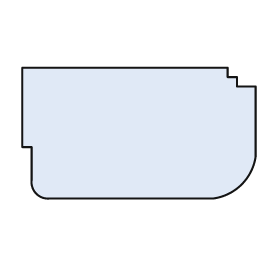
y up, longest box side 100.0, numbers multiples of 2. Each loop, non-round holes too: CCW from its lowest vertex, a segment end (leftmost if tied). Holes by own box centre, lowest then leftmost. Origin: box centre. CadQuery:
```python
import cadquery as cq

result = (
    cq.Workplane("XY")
    .moveTo(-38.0, -28.0)
    .lineTo(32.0, -28.0)
    .threePointArc((44.0, -22.0), (50.0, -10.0))
    .lineTo(50.0, 20.0)
    .lineTo(42.0, 20.0)
    .lineTo(42.0, 24.0)
    .lineTo(38.0, 24.0)
    .lineTo(38.0, 28.0)
    .lineTo(-50.0, 28.0)
    .lineTo(-50.0, -6.0)
    .lineTo(-46.0, -6.0)
    .lineTo(-46.0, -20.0)
    .threePointArc((-44.0, -26.0), (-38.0, -28.0))
    .close()
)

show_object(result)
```